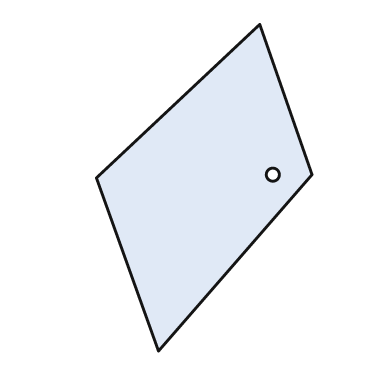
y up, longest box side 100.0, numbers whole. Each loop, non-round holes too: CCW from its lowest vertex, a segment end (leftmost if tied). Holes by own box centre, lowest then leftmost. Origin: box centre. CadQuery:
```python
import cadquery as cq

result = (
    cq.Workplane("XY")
    .moveTo(-14.0, -50.0)
    .lineTo(33.0, 4.0)
    .lineTo(17.0, 50.0)
    .lineTo(-33.0, 3.0)
    .close()
    .moveTo(21.0, 4.0)
    .circle(2.0)
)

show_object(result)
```